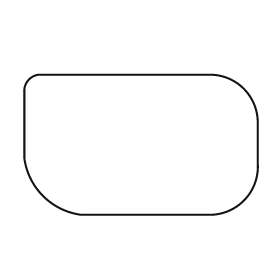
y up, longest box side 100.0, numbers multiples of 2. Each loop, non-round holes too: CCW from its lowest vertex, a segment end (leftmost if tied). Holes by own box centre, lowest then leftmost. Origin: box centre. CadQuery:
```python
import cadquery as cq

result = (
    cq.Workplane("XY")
    .moveTo(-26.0, -30.0)
    .lineTo(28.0, -30.0)
    .threePointArc((44.0, -24.0), (50.0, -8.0))
    .lineTo(50.0, 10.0)
    .threePointArc((44.0, 24.0), (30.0, 30.0))
    .lineTo(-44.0, 30.0)
    .threePointArc((-48.0, 28.0), (-50.0, 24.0))
    .lineTo(-50.0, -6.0)
    .threePointArc((-42.0, -22.0), (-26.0, -30.0))
    .close()
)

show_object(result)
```